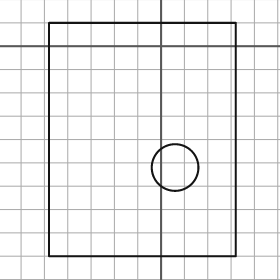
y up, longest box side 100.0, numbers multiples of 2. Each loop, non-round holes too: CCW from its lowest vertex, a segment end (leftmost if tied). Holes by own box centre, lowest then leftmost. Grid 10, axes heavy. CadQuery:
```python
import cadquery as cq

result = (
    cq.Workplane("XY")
    .moveTo(-48.0, -90.0)
    .lineTo(32.0, -90.0)
    .lineTo(32.0, 10.0)
    .lineTo(-48.0, 10.0)
    .close()
    .moveTo(6.0, -52.0)
    .circle(10.0)
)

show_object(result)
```